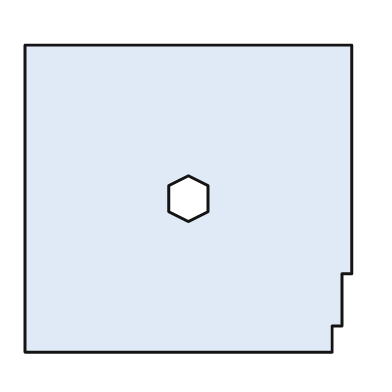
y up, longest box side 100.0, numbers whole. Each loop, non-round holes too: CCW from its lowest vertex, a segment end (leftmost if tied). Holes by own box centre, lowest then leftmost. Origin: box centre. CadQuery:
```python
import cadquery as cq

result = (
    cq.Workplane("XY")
    .moveTo(-50.0, -47.0)
    .lineTo(44.0, -47.0)
    .lineTo(44.0, -39.0)
    .lineTo(47.0, -39.0)
    .lineTo(47.0, -23.0)
    .lineTo(50.0, -23.0)
    .lineTo(50.0, 47.0)
    .lineTo(-50.0, 47.0)
    .close()
    .moveTo(0.0, -7.0)
    .lineTo(6.0, -4.0)
    .lineTo(6.0, 4.0)
    .lineTo(0.0, 7.0)
    .lineTo(-6.0, 4.0)
    .lineTo(-6.0, -4.0)
    .close()
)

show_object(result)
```